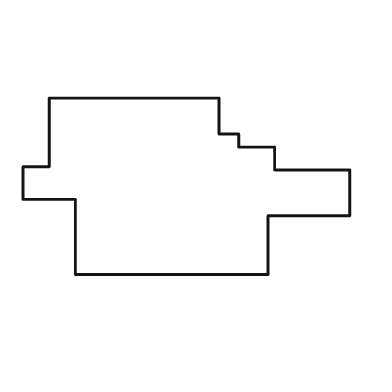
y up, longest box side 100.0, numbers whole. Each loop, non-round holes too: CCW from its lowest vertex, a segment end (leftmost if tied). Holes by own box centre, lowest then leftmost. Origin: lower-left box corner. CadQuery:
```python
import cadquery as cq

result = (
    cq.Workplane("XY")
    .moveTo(16.0, 0.0)
    .lineTo(75.0, 0.0)
    .lineTo(75.0, 18.0)
    .lineTo(100.0, 18.0)
    .lineTo(100.0, 32.0)
    .lineTo(77.0, 32.0)
    .lineTo(77.0, 39.0)
    .lineTo(66.0, 39.0)
    .lineTo(66.0, 43.0)
    .lineTo(60.0, 43.0)
    .lineTo(60.0, 54.0)
    .lineTo(8.0, 54.0)
    .lineTo(8.0, 33.0)
    .lineTo(0.0, 33.0)
    .lineTo(0.0, 23.0)
    .lineTo(16.0, 23.0)
    .close()
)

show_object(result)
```